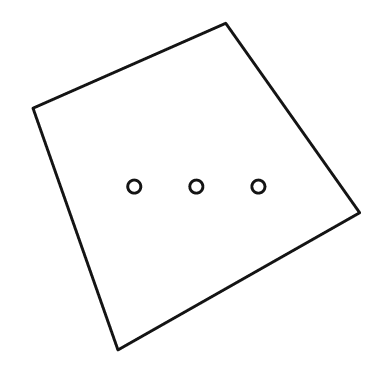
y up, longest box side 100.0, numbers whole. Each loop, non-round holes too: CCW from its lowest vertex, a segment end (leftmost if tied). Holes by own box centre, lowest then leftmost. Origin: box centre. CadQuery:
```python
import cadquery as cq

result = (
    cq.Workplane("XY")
    .moveTo(-24.0, -50.0)
    .lineTo(50.0, -8.0)
    .lineTo(9.0, 50.0)
    .lineTo(-50.0, 24.0)
    .close()
    .moveTo(-19.0, 0.0)
    .circle(2.0)
    .moveTo(0.0, 0.0)
    .circle(2.0)
    .moveTo(19.0, 0.0)
    .circle(2.0)
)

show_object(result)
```